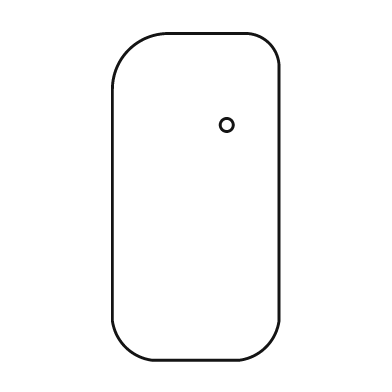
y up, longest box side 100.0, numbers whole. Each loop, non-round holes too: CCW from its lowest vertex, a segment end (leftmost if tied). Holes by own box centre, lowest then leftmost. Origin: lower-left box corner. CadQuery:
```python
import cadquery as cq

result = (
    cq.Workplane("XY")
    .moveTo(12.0, 0.0)
    .lineTo(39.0, 0.0)
    .threePointArc((47.0, 4.0), (51.0, 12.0))
    .lineTo(51.0, 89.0)
    .threePointArc((48.0, 97.0), (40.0, 100.0))
    .lineTo(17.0, 100.0)
    .threePointArc((5.0, 95.0), (0.0, 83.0))
    .lineTo(0.0, 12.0)
    .threePointArc((4.0, 4.0), (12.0, 0.0))
    .close()
    .moveTo(35.0, 72.0)
    .circle(2.0)
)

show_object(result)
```